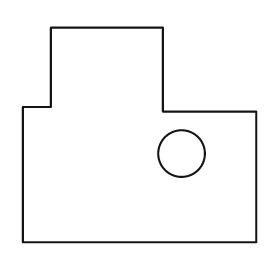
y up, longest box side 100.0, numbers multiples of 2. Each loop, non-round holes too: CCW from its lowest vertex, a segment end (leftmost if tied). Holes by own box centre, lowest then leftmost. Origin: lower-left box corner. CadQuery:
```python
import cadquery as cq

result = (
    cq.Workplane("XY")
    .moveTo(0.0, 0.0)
    .lineTo(100.0, 0.0)
    .lineTo(100.0, 56.0)
    .lineTo(60.0, 56.0)
    .lineTo(60.0, 92.0)
    .lineTo(12.0, 92.0)
    .lineTo(12.0, 58.0)
    .lineTo(0.0, 58.0)
    .close()
    .moveTo(68.0, 38.0)
    .circle(10.0)
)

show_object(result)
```